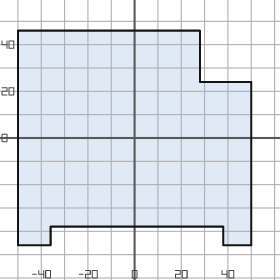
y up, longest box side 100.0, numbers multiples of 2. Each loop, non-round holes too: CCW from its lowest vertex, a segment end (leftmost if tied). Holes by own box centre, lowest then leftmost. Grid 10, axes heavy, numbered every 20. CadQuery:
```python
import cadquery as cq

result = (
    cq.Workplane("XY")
    .moveTo(-50.0, -46.0)
    .lineTo(-36.0, -46.0)
    .lineTo(-36.0, -38.0)
    .lineTo(38.0, -38.0)
    .lineTo(38.0, -46.0)
    .lineTo(50.0, -46.0)
    .lineTo(50.0, 24.0)
    .lineTo(28.0, 24.0)
    .lineTo(28.0, 46.0)
    .lineTo(-50.0, 46.0)
    .close()
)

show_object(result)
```